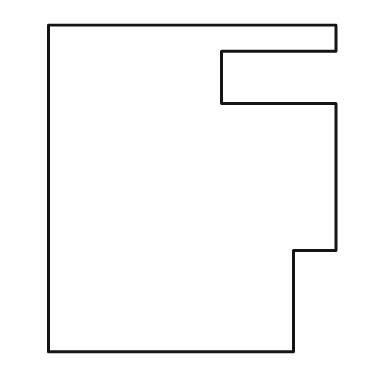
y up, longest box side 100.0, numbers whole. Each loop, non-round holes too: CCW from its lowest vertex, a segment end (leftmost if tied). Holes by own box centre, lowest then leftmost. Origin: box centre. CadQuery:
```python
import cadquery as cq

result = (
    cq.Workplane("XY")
    .moveTo(-44.0, -50.0)
    .lineTo(31.0, -50.0)
    .lineTo(31.0, -19.0)
    .lineTo(44.0, -19.0)
    .lineTo(44.0, 26.0)
    .lineTo(9.0, 26.0)
    .lineTo(9.0, 42.0)
    .lineTo(44.0, 42.0)
    .lineTo(44.0, 50.0)
    .lineTo(-44.0, 50.0)
    .close()
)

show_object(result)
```